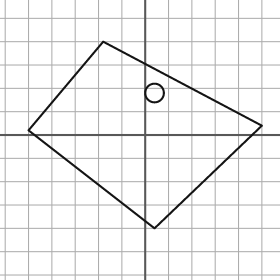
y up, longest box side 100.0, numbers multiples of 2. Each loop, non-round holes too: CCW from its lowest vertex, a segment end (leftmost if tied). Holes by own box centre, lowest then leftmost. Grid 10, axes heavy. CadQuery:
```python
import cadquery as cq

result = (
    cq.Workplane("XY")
    .moveTo(4.0, -40.0)
    .lineTo(50.0, 4.0)
    .lineTo(-18.0, 40.0)
    .lineTo(-50.0, 2.0)
    .close()
    .moveTo(4.0, 18.0)
    .circle(4.0)
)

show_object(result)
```